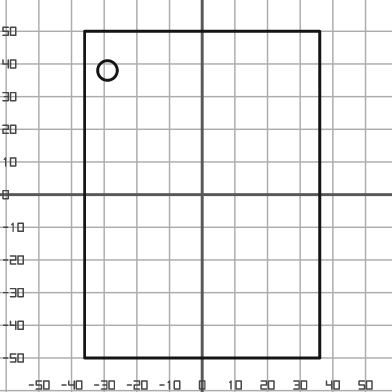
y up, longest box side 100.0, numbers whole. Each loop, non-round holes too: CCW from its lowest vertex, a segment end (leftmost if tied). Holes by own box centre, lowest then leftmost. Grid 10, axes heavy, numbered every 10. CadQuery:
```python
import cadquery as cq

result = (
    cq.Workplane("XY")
    .moveTo(-36.0, -50.0)
    .lineTo(36.0, -50.0)
    .lineTo(36.0, 50.0)
    .lineTo(-36.0, 50.0)
    .close()
    .moveTo(-29.0, 38.0)
    .circle(3.0)
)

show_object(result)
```